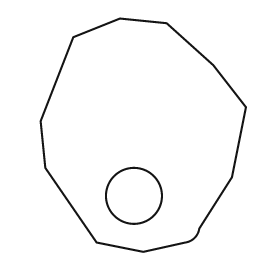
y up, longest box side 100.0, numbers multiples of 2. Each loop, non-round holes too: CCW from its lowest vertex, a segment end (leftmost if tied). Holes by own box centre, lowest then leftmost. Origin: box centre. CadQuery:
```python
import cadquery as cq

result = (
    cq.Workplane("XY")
    .moveTo(0.0, -50.0)
    .lineTo(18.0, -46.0)
    .threePointArc((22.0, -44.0), (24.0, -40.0))
    .lineTo(38.0, -18.0)
    .lineTo(44.0, 12.0)
    .lineTo(30.0, 30.0)
    .lineTo(10.0, 48.0)
    .lineTo(-10.0, 50.0)
    .lineTo(-30.0, 42.0)
    .lineTo(-44.0, 6.0)
    .lineTo(-42.0, -14.0)
    .lineTo(-20.0, -46.0)
    .close()
    .moveTo(-4.0, -26.0)
    .circle(12.0)
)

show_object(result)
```